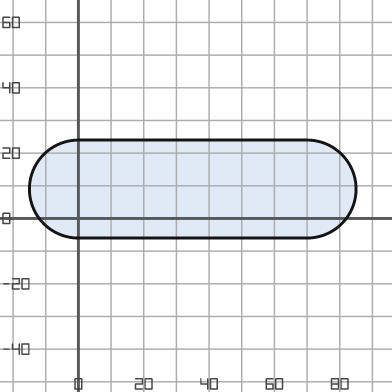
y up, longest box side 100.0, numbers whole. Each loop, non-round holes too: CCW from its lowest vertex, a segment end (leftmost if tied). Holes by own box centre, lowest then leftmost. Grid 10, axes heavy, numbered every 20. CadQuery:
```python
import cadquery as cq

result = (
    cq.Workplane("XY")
    .moveTo(0.0, -6.0)
    .lineTo(70.0, -6.0)
    .threePointArc((85.0, 9.0), (70.0, 24.0))
    .lineTo(0.0, 24.0)
    .threePointArc((-15.0, 9.0), (0.0, -6.0))
    .close()
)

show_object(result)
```